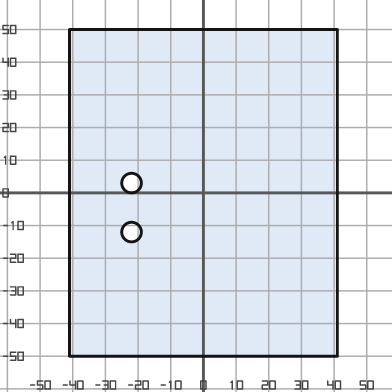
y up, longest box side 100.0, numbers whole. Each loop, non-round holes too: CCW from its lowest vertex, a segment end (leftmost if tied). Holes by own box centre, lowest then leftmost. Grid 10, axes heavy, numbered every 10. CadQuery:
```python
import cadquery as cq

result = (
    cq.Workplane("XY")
    .moveTo(-41.0, -50.0)
    .lineTo(41.0, -50.0)
    .lineTo(41.0, 50.0)
    .lineTo(-41.0, 50.0)
    .close()
    .moveTo(-22.0, -12.0)
    .circle(3.0)
    .moveTo(-22.0, 3.0)
    .circle(3.0)
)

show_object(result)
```